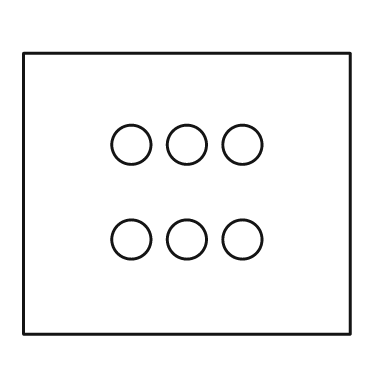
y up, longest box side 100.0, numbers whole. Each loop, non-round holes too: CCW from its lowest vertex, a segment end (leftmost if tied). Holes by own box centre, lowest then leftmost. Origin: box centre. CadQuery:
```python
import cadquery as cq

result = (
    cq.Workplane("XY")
    .moveTo(-50.0, -43.0)
    .lineTo(50.0, -43.0)
    .lineTo(50.0, 43.0)
    .lineTo(-50.0, 43.0)
    .close()
    .moveTo(-17.0, -14.0)
    .circle(6.0)
    .moveTo(0.0, -14.0)
    .circle(6.0)
    .moveTo(17.0, -14.0)
    .circle(6.0)
    .moveTo(-17.0, 15.0)
    .circle(6.0)
    .moveTo(0.0, 15.0)
    .circle(6.0)
    .moveTo(17.0, 15.0)
    .circle(6.0)
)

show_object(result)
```